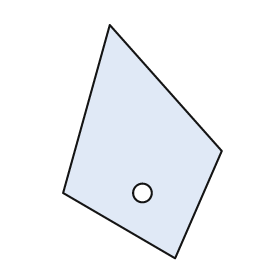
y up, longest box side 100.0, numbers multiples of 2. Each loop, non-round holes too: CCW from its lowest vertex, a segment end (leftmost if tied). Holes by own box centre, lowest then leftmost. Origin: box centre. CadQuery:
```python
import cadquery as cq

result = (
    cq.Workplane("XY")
    .moveTo(14.0, -50.0)
    .lineTo(34.0, -4.0)
    .lineTo(-14.0, 50.0)
    .lineTo(-34.0, -22.0)
    .close()
    .moveTo(0.0, -22.0)
    .circle(4.0)
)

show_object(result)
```